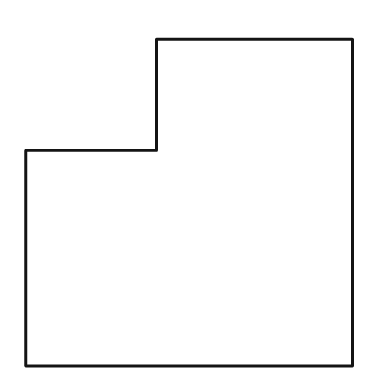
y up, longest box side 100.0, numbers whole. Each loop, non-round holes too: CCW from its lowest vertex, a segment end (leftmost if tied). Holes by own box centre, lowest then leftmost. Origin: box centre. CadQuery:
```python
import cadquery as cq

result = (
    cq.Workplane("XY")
    .moveTo(-50.0, -50.0)
    .lineTo(50.0, -50.0)
    .lineTo(50.0, 50.0)
    .lineTo(-10.0, 50.0)
    .lineTo(-10.0, 16.0)
    .lineTo(-50.0, 16.0)
    .close()
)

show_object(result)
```